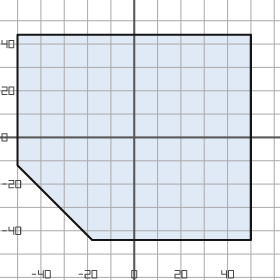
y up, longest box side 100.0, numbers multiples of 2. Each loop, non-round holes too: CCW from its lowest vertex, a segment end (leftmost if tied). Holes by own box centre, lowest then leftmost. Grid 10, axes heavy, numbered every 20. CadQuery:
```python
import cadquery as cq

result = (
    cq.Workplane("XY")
    .moveTo(-18.0, -44.0)
    .lineTo(50.0, -44.0)
    .lineTo(50.0, 44.0)
    .lineTo(-50.0, 44.0)
    .lineTo(-50.0, -12.0)
    .close()
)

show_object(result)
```